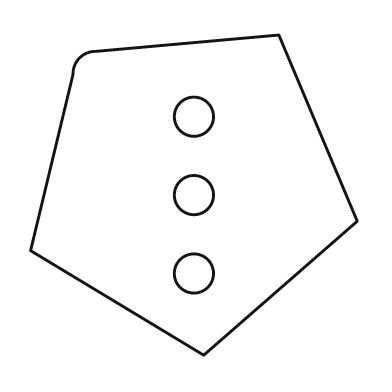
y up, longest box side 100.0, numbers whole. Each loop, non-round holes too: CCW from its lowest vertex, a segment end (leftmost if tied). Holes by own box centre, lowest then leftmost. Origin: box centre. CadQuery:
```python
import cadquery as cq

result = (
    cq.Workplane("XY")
    .moveTo(3.0, -49.0)
    .lineTo(50.0, -8.0)
    .lineTo(26.0, 49.0)
    .lineTo(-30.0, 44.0)
    .threePointArc((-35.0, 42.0), (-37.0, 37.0))
    .lineTo(-50.0, -17.0)
    .close()
    .moveTo(0.0, -24.0)
    .circle(6.0)
    .moveTo(0.0, 0.0)
    .circle(6.0)
    .moveTo(0.0, 24.0)
    .circle(6.0)
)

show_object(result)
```